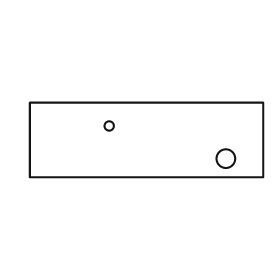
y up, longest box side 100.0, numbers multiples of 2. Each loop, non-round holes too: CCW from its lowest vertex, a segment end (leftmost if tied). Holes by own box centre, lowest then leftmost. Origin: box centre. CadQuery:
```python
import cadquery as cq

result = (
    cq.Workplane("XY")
    .moveTo(-50.0, -16.0)
    .lineTo(50.0, -16.0)
    .lineTo(50.0, 16.0)
    .lineTo(-50.0, 16.0)
    .close()
    .moveTo(34.0, -8.0)
    .circle(4.0)
    .moveTo(-16.0, 6.0)
    .circle(2.0)
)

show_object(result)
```